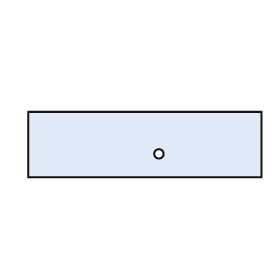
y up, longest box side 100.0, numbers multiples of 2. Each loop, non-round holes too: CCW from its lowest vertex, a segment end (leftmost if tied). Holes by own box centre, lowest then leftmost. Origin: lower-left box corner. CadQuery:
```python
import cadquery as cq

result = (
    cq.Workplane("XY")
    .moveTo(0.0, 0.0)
    .lineTo(100.0, 0.0)
    .lineTo(100.0, 28.0)
    .lineTo(0.0, 28.0)
    .close()
    .moveTo(56.0, 10.0)
    .circle(2.0)
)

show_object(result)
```